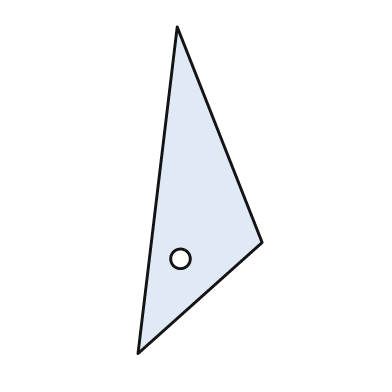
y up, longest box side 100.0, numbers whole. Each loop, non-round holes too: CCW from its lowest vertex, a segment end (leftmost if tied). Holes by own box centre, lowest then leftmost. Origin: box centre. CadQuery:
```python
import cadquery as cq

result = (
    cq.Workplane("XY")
    .moveTo(-19.0, -50.0)
    .lineTo(19.0, -16.0)
    .lineTo(-7.0, 50.0)
    .close()
    .moveTo(-6.0, -21.0)
    .circle(3.0)
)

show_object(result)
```